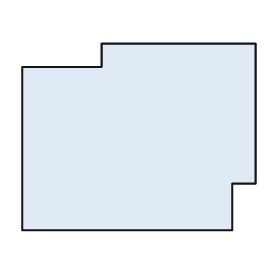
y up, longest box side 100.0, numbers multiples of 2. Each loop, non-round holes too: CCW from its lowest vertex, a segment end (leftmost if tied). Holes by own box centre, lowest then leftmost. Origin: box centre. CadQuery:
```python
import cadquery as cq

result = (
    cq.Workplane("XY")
    .moveTo(-50.0, -40.0)
    .lineTo(40.0, -40.0)
    .lineTo(40.0, -20.0)
    .lineTo(50.0, -20.0)
    .lineTo(50.0, 40.0)
    .lineTo(-16.0, 40.0)
    .lineTo(-16.0, 30.0)
    .lineTo(-50.0, 30.0)
    .close()
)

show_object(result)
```